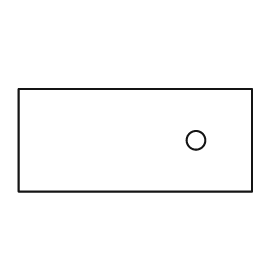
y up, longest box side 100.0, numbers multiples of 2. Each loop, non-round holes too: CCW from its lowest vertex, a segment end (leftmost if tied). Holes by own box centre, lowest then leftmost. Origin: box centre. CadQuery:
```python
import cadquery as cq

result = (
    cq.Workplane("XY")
    .moveTo(-50.0, -22.0)
    .lineTo(50.0, -22.0)
    .lineTo(50.0, 22.0)
    .lineTo(-50.0, 22.0)
    .close()
    .moveTo(26.0, 0.0)
    .circle(4.0)
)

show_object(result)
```